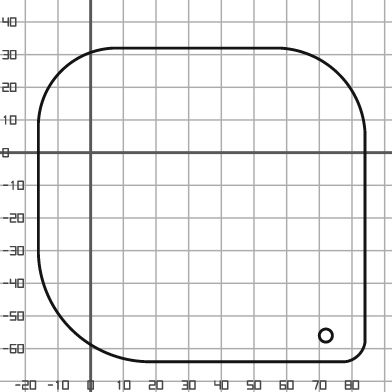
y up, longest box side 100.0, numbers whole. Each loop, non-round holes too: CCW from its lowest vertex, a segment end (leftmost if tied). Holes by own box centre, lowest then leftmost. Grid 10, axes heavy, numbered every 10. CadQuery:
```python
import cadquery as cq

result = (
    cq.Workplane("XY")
    .moveTo(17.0, -64.0)
    .lineTo(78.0, -64.0)
    .threePointArc((82.0, -62.0), (84.0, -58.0))
    .lineTo(84.0, 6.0)
    .threePointArc((76.0, 24.0), (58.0, 32.0))
    .lineTo(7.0, 32.0)
    .threePointArc((-9.0, 25.0), (-16.0, 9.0))
    .lineTo(-16.0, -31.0)
    .threePointArc((-6.0, -54.0), (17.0, -64.0))
    .close()
    .moveTo(72.0, -56.0)
    .circle(2.0)
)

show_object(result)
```